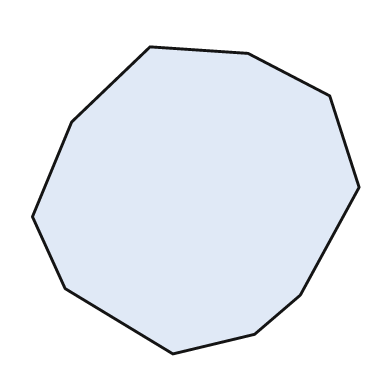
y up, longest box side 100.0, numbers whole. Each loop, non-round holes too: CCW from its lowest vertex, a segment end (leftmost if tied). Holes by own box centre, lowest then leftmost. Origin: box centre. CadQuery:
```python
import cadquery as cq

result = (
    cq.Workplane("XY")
    .moveTo(-7.0, -47.0)
    .lineTo(18.0, -41.0)
    .lineTo(32.0, -29.0)
    .lineTo(50.0, 4.0)
    .lineTo(41.0, 32.0)
    .lineTo(16.0, 45.0)
    .lineTo(-14.0, 47.0)
    .lineTo(-38.0, 24.0)
    .lineTo(-50.0, -5.0)
    .lineTo(-40.0, -27.0)
    .close()
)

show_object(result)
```